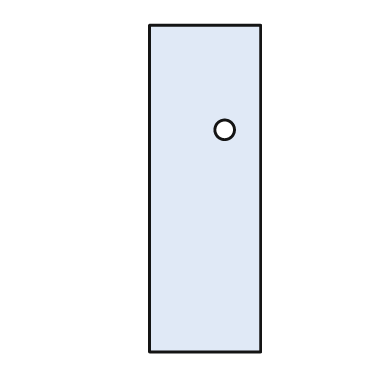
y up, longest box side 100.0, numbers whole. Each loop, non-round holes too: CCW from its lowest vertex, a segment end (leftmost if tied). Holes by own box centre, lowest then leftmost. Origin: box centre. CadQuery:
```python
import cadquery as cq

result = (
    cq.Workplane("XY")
    .moveTo(-17.0, -50.0)
    .lineTo(17.0, -50.0)
    .lineTo(17.0, 50.0)
    .lineTo(-17.0, 50.0)
    .close()
    .moveTo(6.0, 18.0)
    .circle(3.0)
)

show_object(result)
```